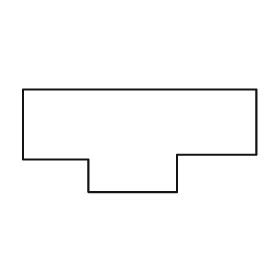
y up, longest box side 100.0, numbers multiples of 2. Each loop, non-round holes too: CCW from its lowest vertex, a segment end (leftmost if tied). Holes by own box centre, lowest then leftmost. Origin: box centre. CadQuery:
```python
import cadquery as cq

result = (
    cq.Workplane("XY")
    .moveTo(-22.0, -22.0)
    .lineTo(16.0, -22.0)
    .lineTo(16.0, -6.0)
    .lineTo(50.0, -6.0)
    .lineTo(50.0, 22.0)
    .lineTo(-50.0, 22.0)
    .lineTo(-50.0, -8.0)
    .lineTo(-22.0, -8.0)
    .close()
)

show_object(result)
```